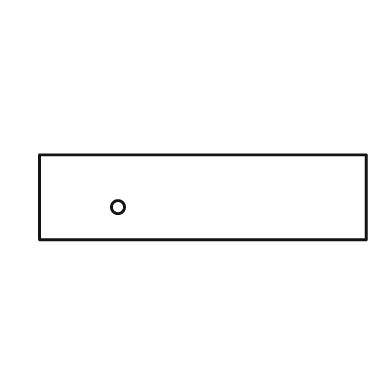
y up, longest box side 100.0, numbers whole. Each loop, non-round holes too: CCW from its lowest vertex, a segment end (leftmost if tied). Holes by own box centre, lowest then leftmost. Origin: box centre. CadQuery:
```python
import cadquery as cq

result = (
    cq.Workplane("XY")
    .moveTo(-50.0, -13.0)
    .lineTo(50.0, -13.0)
    .lineTo(50.0, 13.0)
    .lineTo(-50.0, 13.0)
    .close()
    .moveTo(-26.0, -3.0)
    .circle(2.0)
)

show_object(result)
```